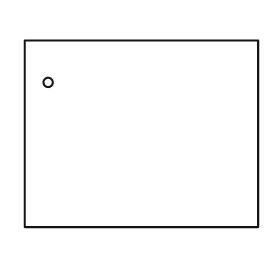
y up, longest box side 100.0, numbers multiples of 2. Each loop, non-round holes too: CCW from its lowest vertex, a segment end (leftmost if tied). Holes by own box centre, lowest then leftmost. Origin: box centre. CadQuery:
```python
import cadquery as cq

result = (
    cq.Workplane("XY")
    .moveTo(-50.0, -40.0)
    .lineTo(50.0, -40.0)
    .lineTo(50.0, 40.0)
    .lineTo(-50.0, 40.0)
    .close()
    .moveTo(-40.0, 22.0)
    .circle(2.0)
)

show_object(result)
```